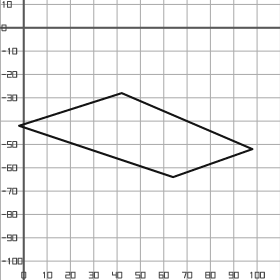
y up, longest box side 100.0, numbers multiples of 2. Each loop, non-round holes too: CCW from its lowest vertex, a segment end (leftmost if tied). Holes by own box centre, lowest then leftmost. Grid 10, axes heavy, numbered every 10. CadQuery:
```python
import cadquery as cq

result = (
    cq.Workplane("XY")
    .moveTo(64.0, -64.0)
    .lineTo(98.0, -52.0)
    .lineTo(42.0, -28.0)
    .lineTo(-2.0, -42.0)
    .close()
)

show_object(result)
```